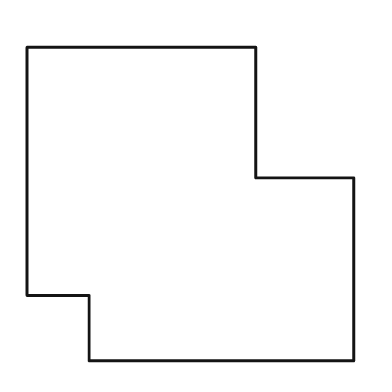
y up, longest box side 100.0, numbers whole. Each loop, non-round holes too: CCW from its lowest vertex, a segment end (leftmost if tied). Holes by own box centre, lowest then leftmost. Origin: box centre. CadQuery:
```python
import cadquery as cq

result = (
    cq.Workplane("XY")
    .moveTo(-31.0, -48.0)
    .lineTo(50.0, -48.0)
    .lineTo(50.0, 8.0)
    .lineTo(20.0, 8.0)
    .lineTo(20.0, 48.0)
    .lineTo(-50.0, 48.0)
    .lineTo(-50.0, -28.0)
    .lineTo(-31.0, -28.0)
    .close()
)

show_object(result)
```